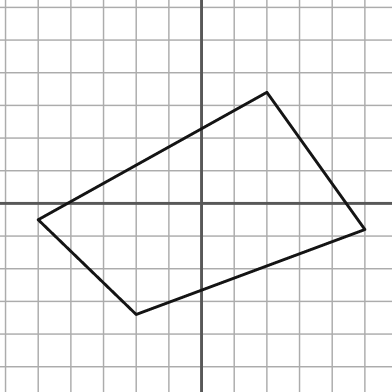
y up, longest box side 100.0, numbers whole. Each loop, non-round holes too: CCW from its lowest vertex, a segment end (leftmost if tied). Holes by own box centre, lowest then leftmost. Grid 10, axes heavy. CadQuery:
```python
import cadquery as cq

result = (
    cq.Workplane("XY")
    .moveTo(-20.0, -34.0)
    .lineTo(50.0, -8.0)
    .lineTo(20.0, 34.0)
    .lineTo(-50.0, -5.0)
    .close()
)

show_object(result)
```